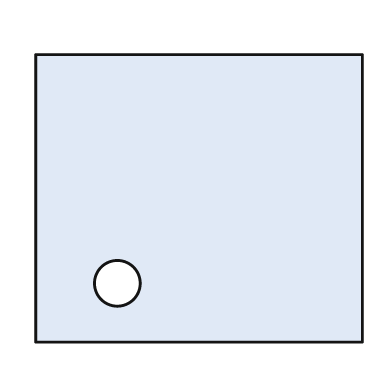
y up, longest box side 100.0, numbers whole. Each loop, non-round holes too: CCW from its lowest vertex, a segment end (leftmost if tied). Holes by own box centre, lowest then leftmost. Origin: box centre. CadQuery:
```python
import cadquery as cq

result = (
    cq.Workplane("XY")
    .moveTo(-50.0, -44.0)
    .lineTo(50.0, -44.0)
    .lineTo(50.0, 44.0)
    .lineTo(-50.0, 44.0)
    .close()
    .moveTo(-25.0, -26.0)
    .circle(7.0)
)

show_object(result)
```